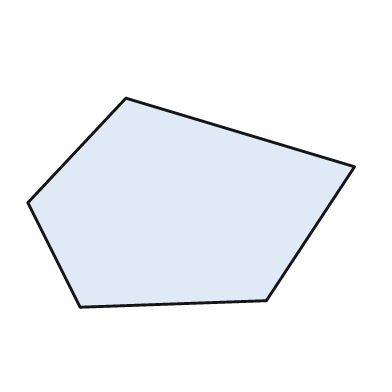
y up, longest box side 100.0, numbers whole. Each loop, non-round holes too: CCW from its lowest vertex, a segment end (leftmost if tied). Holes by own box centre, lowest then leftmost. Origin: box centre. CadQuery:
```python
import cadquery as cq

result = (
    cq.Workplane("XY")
    .moveTo(-34.0, -32.0)
    .lineTo(23.0, -30.0)
    .lineTo(50.0, 11.0)
    .lineTo(-20.0, 32.0)
    .lineTo(-50.0, 0.0)
    .close()
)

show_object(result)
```